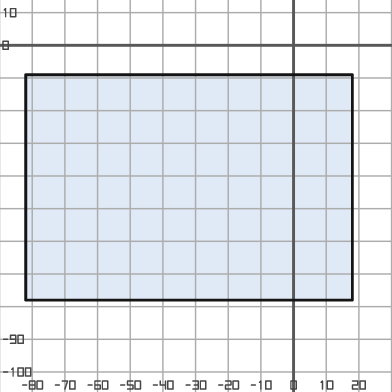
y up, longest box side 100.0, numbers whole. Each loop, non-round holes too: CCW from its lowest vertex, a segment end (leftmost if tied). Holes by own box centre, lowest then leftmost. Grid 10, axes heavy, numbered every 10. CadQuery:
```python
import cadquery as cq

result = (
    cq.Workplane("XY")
    .moveTo(-82.0, -78.0)
    .lineTo(18.0, -78.0)
    .lineTo(18.0, -9.0)
    .lineTo(-82.0, -9.0)
    .close()
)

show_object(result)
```